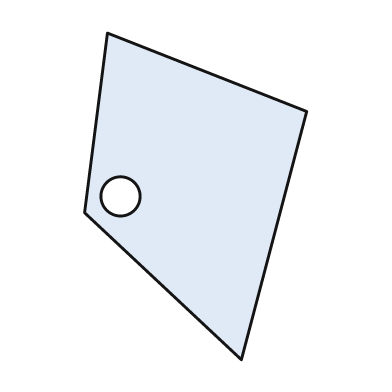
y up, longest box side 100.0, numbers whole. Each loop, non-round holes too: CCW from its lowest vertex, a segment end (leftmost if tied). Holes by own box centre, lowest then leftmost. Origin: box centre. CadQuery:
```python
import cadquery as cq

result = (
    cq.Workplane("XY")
    .moveTo(14.0, -50.0)
    .lineTo(34.0, 26.0)
    .lineTo(-27.0, 50.0)
    .lineTo(-34.0, -5.0)
    .close()
    .moveTo(-23.0, 0.0)
    .circle(6.0)
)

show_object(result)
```